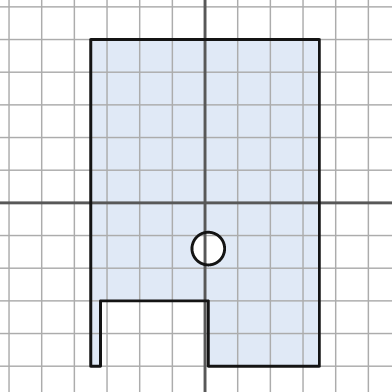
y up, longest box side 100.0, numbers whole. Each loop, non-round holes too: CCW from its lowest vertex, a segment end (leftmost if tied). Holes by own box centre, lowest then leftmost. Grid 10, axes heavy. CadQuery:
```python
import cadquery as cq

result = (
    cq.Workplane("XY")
    .moveTo(-35.0, -50.0)
    .lineTo(-32.0, -50.0)
    .lineTo(-32.0, -30.0)
    .lineTo(1.0, -30.0)
    .lineTo(1.0, -50.0)
    .lineTo(35.0, -50.0)
    .lineTo(35.0, 50.0)
    .lineTo(-35.0, 50.0)
    .close()
    .moveTo(1.0, -14.0)
    .circle(5.0)
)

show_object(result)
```